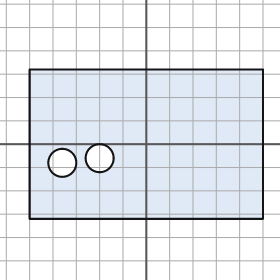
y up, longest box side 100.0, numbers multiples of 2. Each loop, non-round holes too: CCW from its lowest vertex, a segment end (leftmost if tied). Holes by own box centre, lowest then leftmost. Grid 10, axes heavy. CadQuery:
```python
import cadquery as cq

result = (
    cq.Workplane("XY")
    .moveTo(-50.0, -32.0)
    .lineTo(50.0, -32.0)
    .lineTo(50.0, 32.0)
    .lineTo(-50.0, 32.0)
    .close()
    .moveTo(-36.0, -8.0)
    .circle(6.0)
    .moveTo(-20.0, -6.0)
    .circle(6.0)
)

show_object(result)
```